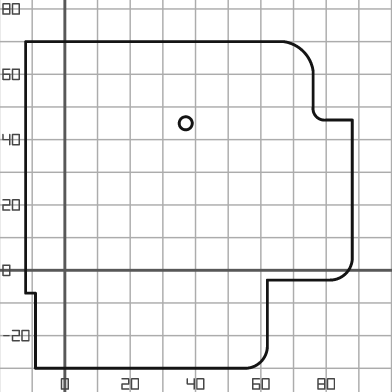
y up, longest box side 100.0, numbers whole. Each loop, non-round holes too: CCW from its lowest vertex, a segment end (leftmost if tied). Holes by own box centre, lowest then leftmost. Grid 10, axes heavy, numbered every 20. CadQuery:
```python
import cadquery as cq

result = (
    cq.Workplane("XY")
    .moveTo(-9.0, -30.0)
    .lineTo(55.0, -30.0)
    .threePointArc((60.0, -28.0), (62.0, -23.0))
    .lineTo(62.0, -3.0)
    .lineTo(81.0, -3.0)
    .threePointArc((86.0, -1.0), (88.0, 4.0))
    .lineTo(88.0, 46.0)
    .lineTo(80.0, 46.0)
    .threePointArc((77.0, 47.0), (76.0, 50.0))
    .lineTo(76.0, 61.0)
    .threePointArc((73.0, 67.0), (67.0, 70.0))
    .lineTo(-12.0, 70.0)
    .lineTo(-12.0, -7.0)
    .lineTo(-9.0, -7.0)
    .close()
    .moveTo(37.0, 45.0)
    .circle(2.0)
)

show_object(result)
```